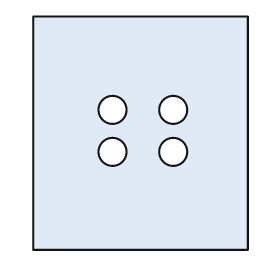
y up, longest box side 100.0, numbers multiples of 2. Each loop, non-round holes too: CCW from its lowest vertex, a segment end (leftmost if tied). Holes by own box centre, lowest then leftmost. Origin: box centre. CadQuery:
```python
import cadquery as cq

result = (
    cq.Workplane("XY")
    .moveTo(-46.0, -50.0)
    .lineTo(46.0, -50.0)
    .lineTo(46.0, 50.0)
    .lineTo(-46.0, 50.0)
    .close()
    .moveTo(-12.0, -8.0)
    .circle(6.0)
    .moveTo(14.0, -8.0)
    .circle(6.0)
    .moveTo(-12.0, 10.0)
    .circle(6.0)
    .moveTo(14.0, 10.0)
    .circle(6.0)
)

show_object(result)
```